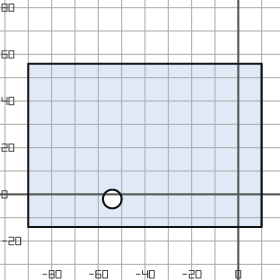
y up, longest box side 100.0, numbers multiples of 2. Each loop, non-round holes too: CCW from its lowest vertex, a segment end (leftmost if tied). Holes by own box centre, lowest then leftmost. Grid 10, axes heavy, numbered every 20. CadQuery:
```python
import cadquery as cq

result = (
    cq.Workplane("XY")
    .moveTo(-90.0, -14.0)
    .lineTo(10.0, -14.0)
    .lineTo(10.0, 56.0)
    .lineTo(-90.0, 56.0)
    .close()
    .moveTo(-54.0, -2.0)
    .circle(4.0)
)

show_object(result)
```